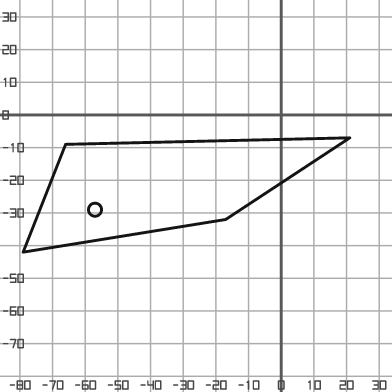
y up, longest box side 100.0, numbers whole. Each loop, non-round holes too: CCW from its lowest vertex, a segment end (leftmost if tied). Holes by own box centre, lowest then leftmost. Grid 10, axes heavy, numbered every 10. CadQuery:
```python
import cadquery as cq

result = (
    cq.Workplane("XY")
    .moveTo(-79.0, -42.0)
    .lineTo(-17.0, -32.0)
    .lineTo(21.0, -7.0)
    .lineTo(-66.0, -9.0)
    .close()
    .moveTo(-57.0, -29.0)
    .circle(2.0)
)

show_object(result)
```